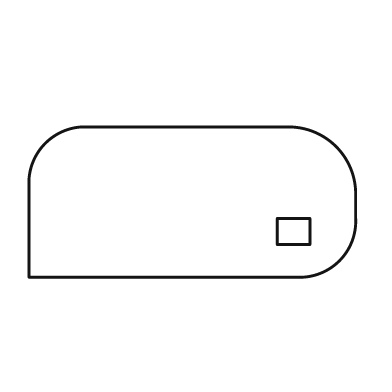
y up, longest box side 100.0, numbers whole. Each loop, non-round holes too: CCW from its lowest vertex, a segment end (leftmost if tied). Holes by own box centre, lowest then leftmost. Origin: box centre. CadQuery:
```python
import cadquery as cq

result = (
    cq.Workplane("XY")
    .moveTo(-50.0, -23.0)
    .lineTo(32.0, -23.0)
    .threePointArc((45.0, -18.0), (50.0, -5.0))
    .lineTo(50.0, 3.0)
    .threePointArc((44.0, 17.0), (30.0, 23.0))
    .lineTo(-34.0, 23.0)
    .threePointArc((-45.0, 18.0), (-50.0, 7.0))
    .close()
    .moveTo(26.0, -13.0)
    .lineTo(36.0, -13.0)
    .lineTo(36.0, -5.0)
    .lineTo(26.0, -5.0)
    .close()
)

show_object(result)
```